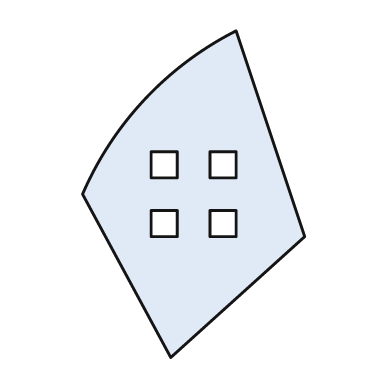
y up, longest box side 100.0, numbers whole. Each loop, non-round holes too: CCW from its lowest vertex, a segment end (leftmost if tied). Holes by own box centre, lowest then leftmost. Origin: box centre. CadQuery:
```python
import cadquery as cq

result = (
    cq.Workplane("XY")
    .moveTo(-7.0, -50.0)
    .lineTo(34.0, -13.0)
    .lineTo(13.0, 50.0)
    .threePointArc((-15.0, 29.0), (-34.0, 0.0))
    .close()
    .moveTo(-13.0, -13.0)
    .lineTo(-5.0, -13.0)
    .lineTo(-5.0, -5.0)
    .lineTo(-13.0, -5.0)
    .close()
    .moveTo(5.0, -13.0)
    .lineTo(13.0, -13.0)
    .lineTo(13.0, -5.0)
    .lineTo(5.0, -5.0)
    .close()
    .moveTo(-13.0, 5.0)
    .lineTo(-5.0, 5.0)
    .lineTo(-5.0, 13.0)
    .lineTo(-13.0, 13.0)
    .close()
    .moveTo(5.0, 5.0)
    .lineTo(13.0, 5.0)
    .lineTo(13.0, 13.0)
    .lineTo(5.0, 13.0)
    .close()
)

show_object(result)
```